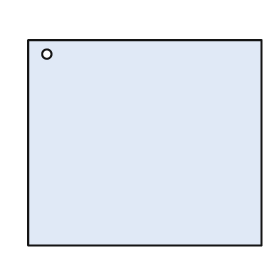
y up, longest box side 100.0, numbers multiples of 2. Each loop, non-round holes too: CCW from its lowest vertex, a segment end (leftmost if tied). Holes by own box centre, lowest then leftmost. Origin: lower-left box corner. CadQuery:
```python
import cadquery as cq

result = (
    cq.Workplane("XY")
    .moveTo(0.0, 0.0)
    .lineTo(100.0, 0.0)
    .lineTo(100.0, 88.0)
    .lineTo(0.0, 88.0)
    .close()
    .moveTo(8.0, 82.0)
    .circle(2.0)
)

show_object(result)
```